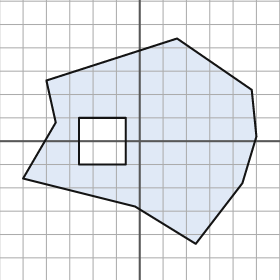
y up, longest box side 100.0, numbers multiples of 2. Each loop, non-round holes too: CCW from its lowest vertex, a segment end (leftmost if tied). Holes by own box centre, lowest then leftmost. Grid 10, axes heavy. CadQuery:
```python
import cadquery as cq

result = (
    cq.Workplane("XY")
    .moveTo(24.0, -44.0)
    .lineTo(44.0, -18.0)
    .lineTo(50.0, 2.0)
    .lineTo(48.0, 22.0)
    .lineTo(16.0, 44.0)
    .lineTo(-40.0, 26.0)
    .lineTo(-36.0, 8.0)
    .lineTo(-50.0, -16.0)
    .lineTo(-2.0, -28.0)
    .close()
    .moveTo(-26.0, -10.0)
    .lineTo(-6.0, -10.0)
    .lineTo(-6.0, 10.0)
    .lineTo(-26.0, 10.0)
    .close()
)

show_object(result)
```